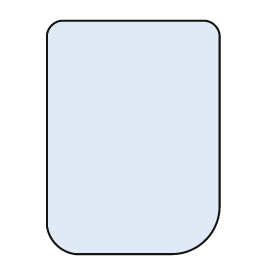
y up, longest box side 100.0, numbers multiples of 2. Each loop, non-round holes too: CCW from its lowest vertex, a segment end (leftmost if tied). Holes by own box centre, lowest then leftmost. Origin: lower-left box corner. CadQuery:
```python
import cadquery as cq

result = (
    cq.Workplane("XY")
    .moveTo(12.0, 0.0)
    .lineTo(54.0, 0.0)
    .threePointArc((68.0, 6.0), (74.0, 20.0))
    .lineTo(74.0, 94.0)
    .threePointArc((72.0, 98.0), (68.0, 100.0))
    .lineTo(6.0, 100.0)
    .threePointArc((2.0, 98.0), (0.0, 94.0))
    .lineTo(0.0, 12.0)
    .threePointArc((4.0, 4.0), (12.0, 0.0))
    .close()
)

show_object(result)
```